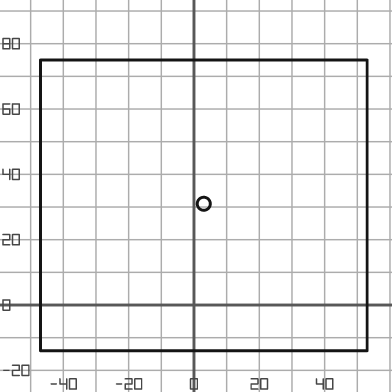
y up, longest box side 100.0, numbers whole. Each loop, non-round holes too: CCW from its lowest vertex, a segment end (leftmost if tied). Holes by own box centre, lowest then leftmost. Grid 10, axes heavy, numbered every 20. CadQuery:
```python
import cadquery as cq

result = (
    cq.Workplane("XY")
    .moveTo(-47.0, -14.0)
    .lineTo(53.0, -14.0)
    .lineTo(53.0, 75.0)
    .lineTo(-47.0, 75.0)
    .close()
    .moveTo(3.0, 31.0)
    .circle(2.0)
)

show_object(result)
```